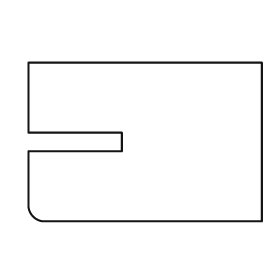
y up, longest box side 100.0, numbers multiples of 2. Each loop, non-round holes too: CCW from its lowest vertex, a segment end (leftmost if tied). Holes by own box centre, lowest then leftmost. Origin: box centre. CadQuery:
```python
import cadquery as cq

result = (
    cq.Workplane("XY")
    .moveTo(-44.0, -34.0)
    .lineTo(50.0, -34.0)
    .lineTo(50.0, 34.0)
    .lineTo(-50.0, 34.0)
    .lineTo(-50.0, 4.0)
    .lineTo(-10.0, 4.0)
    .lineTo(-10.0, -4.0)
    .lineTo(-50.0, -4.0)
    .lineTo(-50.0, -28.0)
    .threePointArc((-48.0, -32.0), (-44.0, -34.0))
    .close()
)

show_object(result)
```